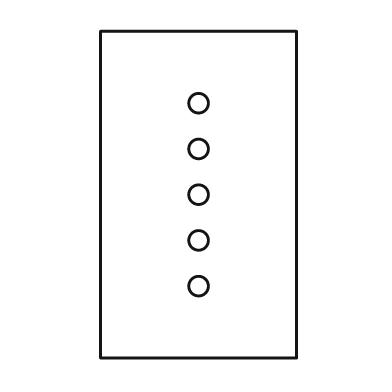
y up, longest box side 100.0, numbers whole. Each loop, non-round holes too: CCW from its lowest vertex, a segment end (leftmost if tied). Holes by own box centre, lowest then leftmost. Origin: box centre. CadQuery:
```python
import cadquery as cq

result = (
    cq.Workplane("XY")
    .moveTo(-30.0, -50.0)
    .lineTo(30.0, -50.0)
    .lineTo(30.0, 50.0)
    .lineTo(-30.0, 50.0)
    .close()
    .moveTo(0.0, -28.0)
    .circle(3.0)
    .moveTo(0.0, -14.0)
    .circle(3.0)
    .moveTo(0.0, 0.0)
    .circle(3.0)
    .moveTo(0.0, 14.0)
    .circle(3.0)
    .moveTo(0.0, 28.0)
    .circle(3.0)
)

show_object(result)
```